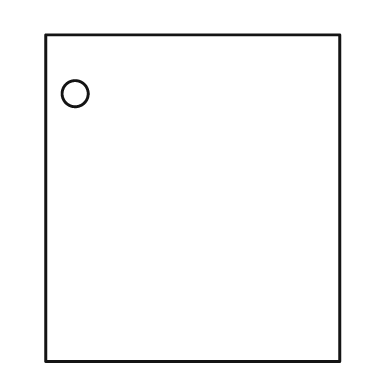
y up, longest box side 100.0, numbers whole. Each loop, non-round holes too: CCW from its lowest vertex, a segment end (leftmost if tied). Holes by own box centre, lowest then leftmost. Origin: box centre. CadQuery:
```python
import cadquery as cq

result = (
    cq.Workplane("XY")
    .moveTo(-45.0, -50.0)
    .lineTo(45.0, -50.0)
    .lineTo(45.0, 50.0)
    .lineTo(-45.0, 50.0)
    .close()
    .moveTo(-36.0, 32.0)
    .circle(4.0)
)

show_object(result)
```